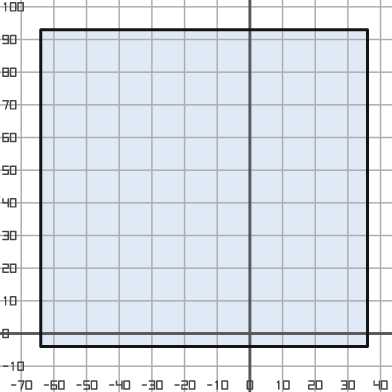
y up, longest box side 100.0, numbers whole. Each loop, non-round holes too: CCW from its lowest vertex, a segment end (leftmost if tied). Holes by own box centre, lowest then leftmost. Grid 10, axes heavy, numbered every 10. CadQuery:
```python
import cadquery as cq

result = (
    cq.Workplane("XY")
    .moveTo(-64.0, -4.0)
    .lineTo(36.0, -4.0)
    .lineTo(36.0, 93.0)
    .lineTo(-64.0, 93.0)
    .close()
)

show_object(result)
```